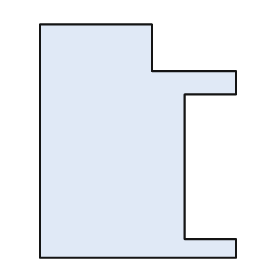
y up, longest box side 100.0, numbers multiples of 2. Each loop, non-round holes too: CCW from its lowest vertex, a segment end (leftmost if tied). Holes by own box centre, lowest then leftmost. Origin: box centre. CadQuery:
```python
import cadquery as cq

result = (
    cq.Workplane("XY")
    .moveTo(-42.0, -50.0)
    .lineTo(42.0, -50.0)
    .lineTo(42.0, -42.0)
    .lineTo(20.0, -42.0)
    .lineTo(20.0, 20.0)
    .lineTo(42.0, 20.0)
    .lineTo(42.0, 30.0)
    .lineTo(6.0, 30.0)
    .lineTo(6.0, 50.0)
    .lineTo(-42.0, 50.0)
    .close()
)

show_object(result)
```